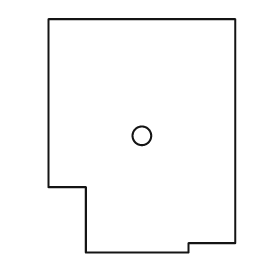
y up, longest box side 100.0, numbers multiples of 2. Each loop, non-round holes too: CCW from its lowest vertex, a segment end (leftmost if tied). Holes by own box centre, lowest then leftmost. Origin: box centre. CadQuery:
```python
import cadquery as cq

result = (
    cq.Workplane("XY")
    .moveTo(-24.0, -50.0)
    .lineTo(20.0, -50.0)
    .lineTo(20.0, -46.0)
    .lineTo(40.0, -46.0)
    .lineTo(40.0, 50.0)
    .lineTo(-40.0, 50.0)
    .lineTo(-40.0, -22.0)
    .lineTo(-24.0, -22.0)
    .close()
    .moveTo(0.0, 0.0)
    .circle(4.0)
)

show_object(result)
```